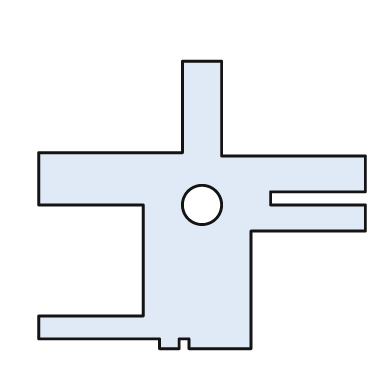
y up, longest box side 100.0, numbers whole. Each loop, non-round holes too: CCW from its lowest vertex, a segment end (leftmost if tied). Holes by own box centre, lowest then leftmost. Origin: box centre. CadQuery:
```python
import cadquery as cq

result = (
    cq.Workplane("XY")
    .moveTo(-13.0, -44.0)
    .lineTo(-7.0, -44.0)
    .lineTo(-7.0, -41.0)
    .lineTo(-4.0, -41.0)
    .lineTo(-4.0, -44.0)
    .lineTo(15.0, -44.0)
    .lineTo(15.0, -8.0)
    .lineTo(50.0, -8.0)
    .lineTo(50.0, 0.0)
    .lineTo(21.0, 0.0)
    .lineTo(21.0, 4.0)
    .lineTo(50.0, 4.0)
    .lineTo(50.0, 15.0)
    .lineTo(6.0, 15.0)
    .lineTo(6.0, 44.0)
    .lineTo(-6.0, 44.0)
    .lineTo(-6.0, 16.0)
    .lineTo(-50.0, 16.0)
    .lineTo(-50.0, 0.0)
    .lineTo(-18.0, 0.0)
    .lineTo(-18.0, -34.0)
    .lineTo(-50.0, -34.0)
    .lineTo(-50.0, -41.0)
    .lineTo(-13.0, -41.0)
    .close()
    .moveTo(0.0, 0.0)
    .circle(6.0)
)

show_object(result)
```